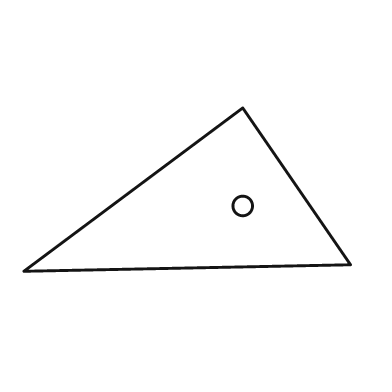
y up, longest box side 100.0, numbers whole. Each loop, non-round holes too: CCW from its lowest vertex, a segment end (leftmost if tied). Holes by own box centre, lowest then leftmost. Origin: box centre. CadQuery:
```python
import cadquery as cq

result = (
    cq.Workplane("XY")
    .moveTo(-50.0, -25.0)
    .lineTo(50.0, -23.0)
    .lineTo(17.0, 25.0)
    .close()
    .moveTo(17.0, -5.0)
    .circle(3.0)
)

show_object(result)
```